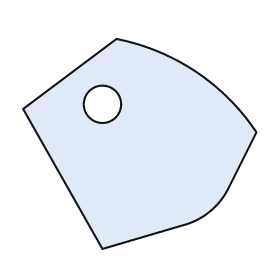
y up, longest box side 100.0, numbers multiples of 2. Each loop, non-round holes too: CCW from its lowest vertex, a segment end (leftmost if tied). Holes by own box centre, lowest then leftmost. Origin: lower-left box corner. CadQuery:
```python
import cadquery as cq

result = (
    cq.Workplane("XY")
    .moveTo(34.0, 0.0)
    .lineTo(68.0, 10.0)
    .threePointArc((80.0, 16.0), (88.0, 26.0))
    .lineTo(100.0, 50.0)
    .threePointArc((74.0, 76.0), (40.0, 90.0))
    .lineTo(0.0, 60.0)
    .close()
    .moveTo(34.0, 62.0)
    .circle(8.0)
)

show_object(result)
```